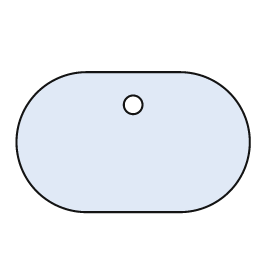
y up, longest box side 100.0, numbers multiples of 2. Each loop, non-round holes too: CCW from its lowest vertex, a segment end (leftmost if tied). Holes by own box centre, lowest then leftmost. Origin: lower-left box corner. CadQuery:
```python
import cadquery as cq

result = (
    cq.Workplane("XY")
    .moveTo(30.0, 0.0)
    .lineTo(70.0, 0.0)
    .threePointArc((100.0, 30.0), (70.0, 60.0))
    .lineTo(30.0, 60.0)
    .threePointArc((0.0, 30.0), (30.0, 0.0))
    .close()
    .moveTo(50.0, 46.0)
    .circle(4.0)
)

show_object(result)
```